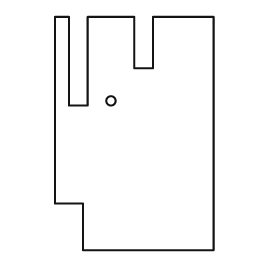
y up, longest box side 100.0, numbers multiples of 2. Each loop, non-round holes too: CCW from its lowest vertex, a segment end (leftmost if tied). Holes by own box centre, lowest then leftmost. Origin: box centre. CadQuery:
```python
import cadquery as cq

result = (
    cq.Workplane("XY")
    .moveTo(-22.0, -50.0)
    .lineTo(34.0, -50.0)
    .lineTo(34.0, 50.0)
    .lineTo(8.0, 50.0)
    .lineTo(8.0, 28.0)
    .lineTo(0.0, 28.0)
    .lineTo(0.0, 50.0)
    .lineTo(-20.0, 50.0)
    .lineTo(-20.0, 12.0)
    .lineTo(-28.0, 12.0)
    .lineTo(-28.0, 50.0)
    .lineTo(-34.0, 50.0)
    .lineTo(-34.0, -30.0)
    .lineTo(-22.0, -30.0)
    .close()
    .moveTo(-10.0, 14.0)
    .circle(2.0)
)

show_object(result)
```